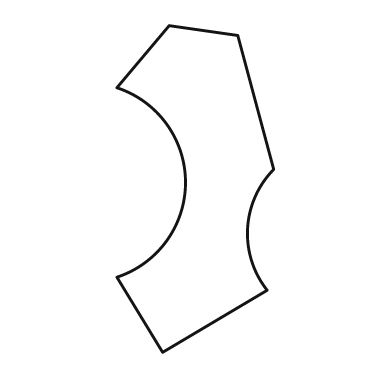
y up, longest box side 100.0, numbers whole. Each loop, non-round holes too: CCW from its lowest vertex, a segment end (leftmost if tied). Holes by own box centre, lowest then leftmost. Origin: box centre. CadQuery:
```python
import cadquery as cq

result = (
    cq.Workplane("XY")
    .moveTo(-10.0, -50.0)
    .lineTo(22.0, -31.0)
    .threePointArc((16.0, -12.0), (24.0, 6.0))
    .lineTo(13.0, 47.0)
    .lineTo(-8.0, 50.0)
    .lineTo(-24.0, 31.0)
    .threePointArc((-3.0, 2.0), (-24.0, -27.0))
    .close()
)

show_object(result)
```